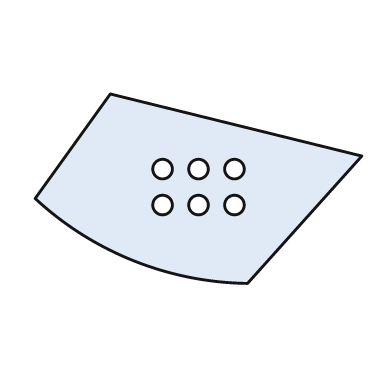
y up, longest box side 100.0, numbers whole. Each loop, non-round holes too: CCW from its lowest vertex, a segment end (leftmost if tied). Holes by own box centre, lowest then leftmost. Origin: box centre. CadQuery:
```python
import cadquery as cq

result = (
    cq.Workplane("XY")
    .moveTo(15.0, -29.0)
    .lineTo(50.0, 10.0)
    .lineTo(-27.0, 29.0)
    .lineTo(-50.0, -3.0)
    .threePointArc((-20.0, -22.0), (15.0, -29.0))
    .close()
    .moveTo(-11.0, -5.0)
    .circle(3.0)
    .moveTo(0.0, -5.0)
    .circle(3.0)
    .moveTo(11.0, -5.0)
    .circle(3.0)
    .moveTo(-11.0, 6.0)
    .circle(3.0)
    .moveTo(0.0, 6.0)
    .circle(3.0)
    .moveTo(11.0, 6.0)
    .circle(3.0)
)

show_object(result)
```